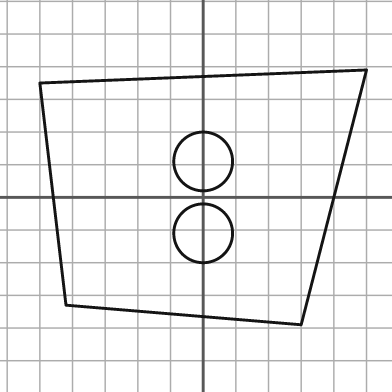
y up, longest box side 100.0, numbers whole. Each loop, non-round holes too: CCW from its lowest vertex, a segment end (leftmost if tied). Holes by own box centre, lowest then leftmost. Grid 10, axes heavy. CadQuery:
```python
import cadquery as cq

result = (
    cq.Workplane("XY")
    .moveTo(30.0, -39.0)
    .lineTo(50.0, 39.0)
    .lineTo(-50.0, 35.0)
    .lineTo(-42.0, -33.0)
    .close()
    .moveTo(0.0, -11.0)
    .circle(9.0)
    .moveTo(0.0, 11.0)
    .circle(9.0)
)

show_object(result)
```